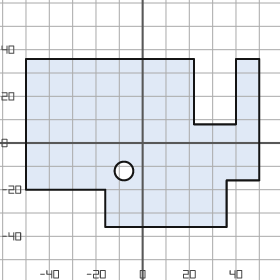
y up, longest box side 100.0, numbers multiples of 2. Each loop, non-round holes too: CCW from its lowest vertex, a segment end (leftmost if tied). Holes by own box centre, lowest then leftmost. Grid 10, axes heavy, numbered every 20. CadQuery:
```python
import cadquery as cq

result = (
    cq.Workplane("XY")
    .moveTo(-16.0, -36.0)
    .lineTo(36.0, -36.0)
    .lineTo(36.0, -16.0)
    .lineTo(50.0, -16.0)
    .lineTo(50.0, 36.0)
    .lineTo(40.0, 36.0)
    .lineTo(40.0, 8.0)
    .lineTo(22.0, 8.0)
    .lineTo(22.0, 36.0)
    .lineTo(-50.0, 36.0)
    .lineTo(-50.0, -20.0)
    .lineTo(-16.0, -20.0)
    .close()
    .moveTo(-8.0, -12.0)
    .circle(4.0)
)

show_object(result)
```